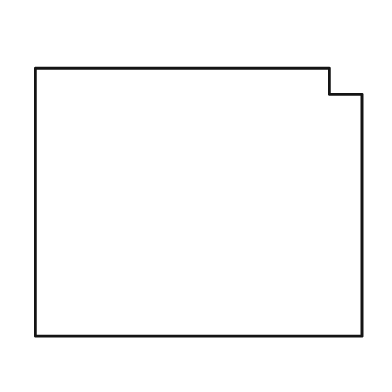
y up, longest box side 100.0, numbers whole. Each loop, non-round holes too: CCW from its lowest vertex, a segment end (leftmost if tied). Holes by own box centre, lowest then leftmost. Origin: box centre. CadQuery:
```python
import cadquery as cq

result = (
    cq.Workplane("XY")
    .moveTo(-50.0, -41.0)
    .lineTo(50.0, -41.0)
    .lineTo(50.0, 33.0)
    .lineTo(40.0, 33.0)
    .lineTo(40.0, 41.0)
    .lineTo(-50.0, 41.0)
    .close()
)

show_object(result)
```